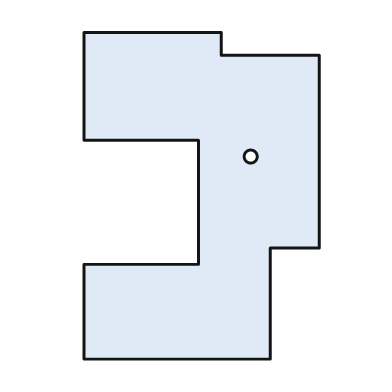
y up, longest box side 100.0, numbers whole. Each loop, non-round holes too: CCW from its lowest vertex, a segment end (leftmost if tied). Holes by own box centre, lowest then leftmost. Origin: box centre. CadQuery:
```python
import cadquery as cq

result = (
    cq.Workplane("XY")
    .moveTo(-36.0, -50.0)
    .lineTo(21.0, -50.0)
    .lineTo(21.0, -16.0)
    .lineTo(36.0, -16.0)
    .lineTo(36.0, 43.0)
    .lineTo(6.0, 43.0)
    .lineTo(6.0, 50.0)
    .lineTo(-36.0, 50.0)
    .lineTo(-36.0, 17.0)
    .lineTo(-1.0, 17.0)
    .lineTo(-1.0, -21.0)
    .lineTo(-36.0, -21.0)
    .close()
    .moveTo(15.0, 12.0)
    .circle(2.0)
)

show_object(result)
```